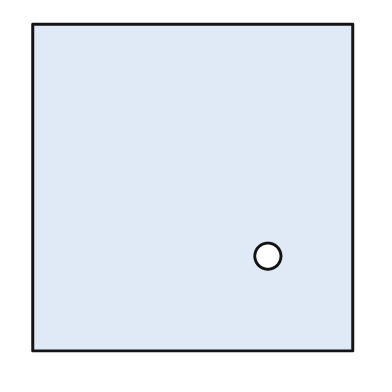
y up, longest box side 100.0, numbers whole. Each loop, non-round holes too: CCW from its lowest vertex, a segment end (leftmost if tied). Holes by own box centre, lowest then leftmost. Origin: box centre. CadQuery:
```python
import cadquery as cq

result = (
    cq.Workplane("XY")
    .moveTo(-49.0, -50.0)
    .lineTo(49.0, -50.0)
    .lineTo(49.0, 50.0)
    .lineTo(-49.0, 50.0)
    .close()
    .moveTo(23.0, -21.0)
    .circle(4.0)
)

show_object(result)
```